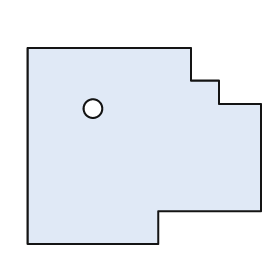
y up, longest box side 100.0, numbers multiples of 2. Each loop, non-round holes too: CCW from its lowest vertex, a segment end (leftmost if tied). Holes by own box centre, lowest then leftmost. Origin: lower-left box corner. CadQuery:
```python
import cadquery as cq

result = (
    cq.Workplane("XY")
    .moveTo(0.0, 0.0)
    .lineTo(56.0, 0.0)
    .lineTo(56.0, 14.0)
    .lineTo(100.0, 14.0)
    .lineTo(100.0, 60.0)
    .lineTo(82.0, 60.0)
    .lineTo(82.0, 70.0)
    .lineTo(70.0, 70.0)
    .lineTo(70.0, 84.0)
    .lineTo(0.0, 84.0)
    .close()
    .moveTo(28.0, 58.0)
    .circle(4.0)
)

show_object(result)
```